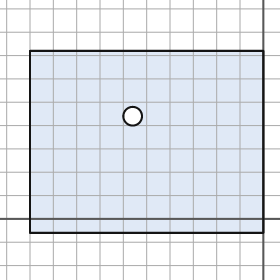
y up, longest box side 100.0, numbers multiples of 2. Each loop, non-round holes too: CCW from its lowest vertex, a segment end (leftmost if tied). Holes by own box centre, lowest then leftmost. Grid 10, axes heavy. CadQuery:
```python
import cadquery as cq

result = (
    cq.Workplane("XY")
    .moveTo(-100.0, -6.0)
    .lineTo(0.0, -6.0)
    .lineTo(0.0, 72.0)
    .lineTo(-100.0, 72.0)
    .close()
    .moveTo(-56.0, 44.0)
    .circle(4.0)
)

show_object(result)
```